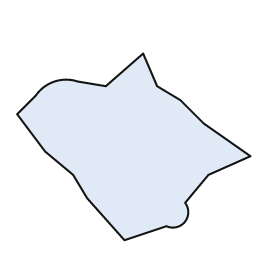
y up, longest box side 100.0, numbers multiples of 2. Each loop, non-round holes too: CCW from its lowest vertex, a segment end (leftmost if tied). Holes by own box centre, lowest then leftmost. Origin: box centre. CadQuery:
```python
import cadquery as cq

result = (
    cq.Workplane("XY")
    .moveTo(-4.0, -40.0)
    .lineTo(14.0, -34.0)
    .threePointArc((22.0, -32.0), (22.0, -24.0))
    .lineTo(32.0, -12.0)
    .lineTo(50.0, -4.0)
    .lineTo(30.0, 10.0)
    .lineTo(20.0, 20.0)
    .lineTo(10.0, 26.0)
    .lineTo(4.0, 40.0)
    .lineTo(-12.0, 26.0)
    .lineTo(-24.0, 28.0)
    .threePointArc((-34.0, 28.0), (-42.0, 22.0))
    .lineTo(-50.0, 14.0)
    .lineTo(-38.0, -2.0)
    .lineTo(-26.0, -12.0)
    .lineTo(-20.0, -22.0)
    .close()
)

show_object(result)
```